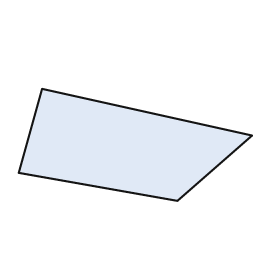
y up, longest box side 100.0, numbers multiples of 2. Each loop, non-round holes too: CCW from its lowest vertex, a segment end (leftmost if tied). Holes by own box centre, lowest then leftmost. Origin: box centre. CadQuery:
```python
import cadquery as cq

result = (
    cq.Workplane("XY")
    .moveTo(18.0, -24.0)
    .lineTo(50.0, 4.0)
    .lineTo(-40.0, 24.0)
    .lineTo(-50.0, -12.0)
    .close()
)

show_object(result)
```